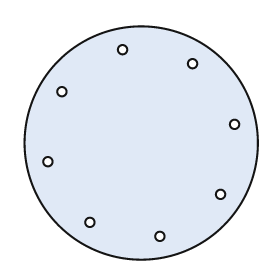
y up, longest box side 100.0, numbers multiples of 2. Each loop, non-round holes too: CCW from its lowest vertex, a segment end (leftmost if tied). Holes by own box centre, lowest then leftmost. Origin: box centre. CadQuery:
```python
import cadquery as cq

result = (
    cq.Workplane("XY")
    .moveTo(0.0, 0.0)
    .circle(50.0)
    .moveTo(8.0, -40.0)
    .circle(2.0)
    .moveTo(-22.0, -34.0)
    .circle(2.0)
    .moveTo(34.0, -22.0)
    .circle(2.0)
    .moveTo(-40.0, -8.0)
    .circle(2.0)
    .moveTo(40.0, 8.0)
    .circle(2.0)
    .moveTo(-34.0, 22.0)
    .circle(2.0)
    .moveTo(22.0, 34.0)
    .circle(2.0)
    .moveTo(-8.0, 40.0)
    .circle(2.0)
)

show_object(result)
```